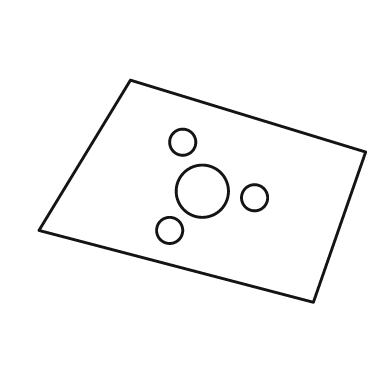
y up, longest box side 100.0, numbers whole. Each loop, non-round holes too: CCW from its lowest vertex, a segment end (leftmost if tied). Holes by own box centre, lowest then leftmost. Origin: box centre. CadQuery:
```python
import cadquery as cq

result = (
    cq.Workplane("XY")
    .moveTo(34.0, -34.0)
    .lineTo(50.0, 12.0)
    .lineTo(-22.0, 34.0)
    .lineTo(-50.0, -12.0)
    .close()
    .moveTo(-10.0, -12.0)
    .circle(4.0)
    .moveTo(16.0, -2.0)
    .circle(4.0)
    .moveTo(0.0, 0.0)
    .circle(8.0)
    .moveTo(-6.0, 15.0)
    .circle(4.0)
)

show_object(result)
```